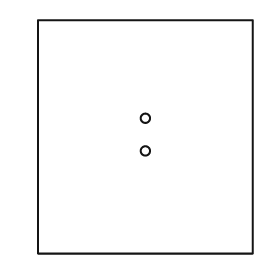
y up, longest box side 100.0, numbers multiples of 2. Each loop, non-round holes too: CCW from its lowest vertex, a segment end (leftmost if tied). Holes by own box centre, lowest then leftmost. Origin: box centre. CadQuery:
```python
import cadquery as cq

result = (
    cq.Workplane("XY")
    .moveTo(-46.0, -50.0)
    .lineTo(46.0, -50.0)
    .lineTo(46.0, 50.0)
    .lineTo(-46.0, 50.0)
    .close()
    .moveTo(0.0, -6.0)
    .circle(2.0)
    .moveTo(0.0, 8.0)
    .circle(2.0)
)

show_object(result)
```